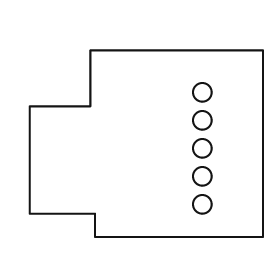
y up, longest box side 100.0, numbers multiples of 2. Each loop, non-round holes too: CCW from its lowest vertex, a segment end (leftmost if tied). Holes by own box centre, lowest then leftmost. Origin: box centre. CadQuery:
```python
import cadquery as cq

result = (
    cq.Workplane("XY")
    .moveTo(-22.0, -40.0)
    .lineTo(50.0, -40.0)
    .lineTo(50.0, 40.0)
    .lineTo(-24.0, 40.0)
    .lineTo(-24.0, 16.0)
    .lineTo(-50.0, 16.0)
    .lineTo(-50.0, -30.0)
    .lineTo(-22.0, -30.0)
    .close()
    .moveTo(24.0, -26.0)
    .circle(4.0)
    .moveTo(24.0, -14.0)
    .circle(4.0)
    .moveTo(24.0, -2.0)
    .circle(4.0)
    .moveTo(24.0, 10.0)
    .circle(4.0)
    .moveTo(24.0, 22.0)
    .circle(4.0)
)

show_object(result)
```